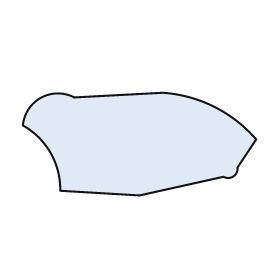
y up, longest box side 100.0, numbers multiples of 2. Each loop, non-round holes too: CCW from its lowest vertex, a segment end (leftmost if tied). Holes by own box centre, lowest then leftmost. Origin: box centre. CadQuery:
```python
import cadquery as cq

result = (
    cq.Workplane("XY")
    .moveTo(0.0, -22.0)
    .lineTo(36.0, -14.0)
    .threePointArc((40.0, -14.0), (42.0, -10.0))
    .lineTo(50.0, 2.0)
    .threePointArc((32.0, 16.0), (10.0, 22.0))
    .lineTo(-28.0, 20.0)
    .threePointArc((-42.0, 20.0), (-50.0, 8.0))
    .threePointArc((-38.0, -4.0), (-34.0, -20.0))
    .close()
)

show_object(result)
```